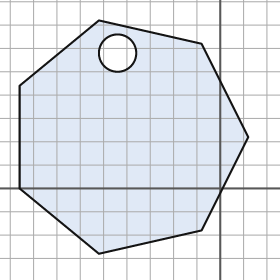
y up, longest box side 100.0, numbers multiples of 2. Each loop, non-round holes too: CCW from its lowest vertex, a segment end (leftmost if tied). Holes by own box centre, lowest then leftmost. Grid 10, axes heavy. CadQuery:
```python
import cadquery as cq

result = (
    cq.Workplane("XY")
    .moveTo(-52.0, -28.0)
    .lineTo(-8.0, -18.0)
    .lineTo(12.0, 22.0)
    .lineTo(-8.0, 62.0)
    .lineTo(-52.0, 72.0)
    .lineTo(-86.0, 44.0)
    .lineTo(-86.0, 0.0)
    .close()
    .moveTo(-44.0, 58.0)
    .circle(8.0)
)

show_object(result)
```